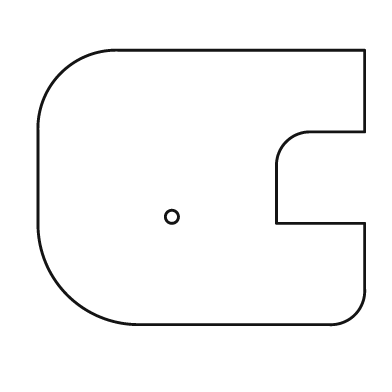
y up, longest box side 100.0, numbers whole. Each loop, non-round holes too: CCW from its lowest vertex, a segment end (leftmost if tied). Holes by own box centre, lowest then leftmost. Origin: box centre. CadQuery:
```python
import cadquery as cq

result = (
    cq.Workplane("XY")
    .moveTo(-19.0, -42.0)
    .lineTo(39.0, -42.0)
    .threePointArc((47.0, -39.0), (50.0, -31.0))
    .lineTo(50.0, -11.0)
    .lineTo(23.0, -11.0)
    .lineTo(23.0, 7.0)
    .threePointArc((26.0, 14.0), (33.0, 17.0))
    .lineTo(50.0, 17.0)
    .lineTo(50.0, 42.0)
    .lineTo(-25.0, 42.0)
    .threePointArc((-43.0, 35.0), (-50.0, 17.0))
    .lineTo(-50.0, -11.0)
    .threePointArc((-41.0, -33.0), (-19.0, -42.0))
    .close()
    .moveTo(-9.0, -9.0)
    .circle(2.0)
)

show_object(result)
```